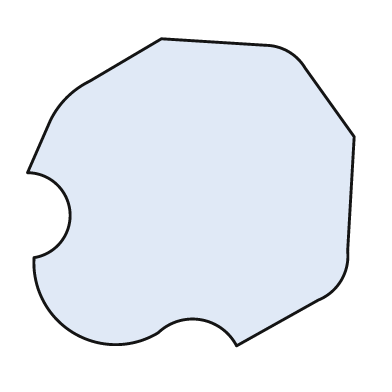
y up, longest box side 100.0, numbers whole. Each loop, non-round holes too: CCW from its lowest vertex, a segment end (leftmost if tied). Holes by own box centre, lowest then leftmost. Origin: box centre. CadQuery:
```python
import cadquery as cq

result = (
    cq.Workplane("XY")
    .moveTo(14.0, -47.0)
    .lineTo(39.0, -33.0)
    .threePointArc((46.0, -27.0), (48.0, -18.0))
    .lineTo(50.0, 17.0)
    .lineTo(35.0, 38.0)
    .threePointArc((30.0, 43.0), (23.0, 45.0))
    .lineTo(-9.0, 47.0)
    .lineTo(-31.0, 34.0)
    .threePointArc((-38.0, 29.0), (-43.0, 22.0))
    .lineTo(-50.0, 6.0)
    .threePointArc((-37.0, -6.0), (-48.0, -20.0))
    .threePointArc((-36.0, -43.0), (-10.0, -43.0))
    .threePointArc((3.0, -39.0), (14.0, -47.0))
    .close()
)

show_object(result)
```